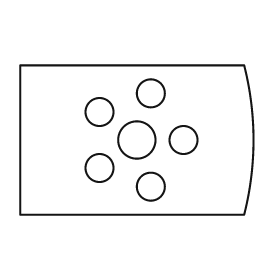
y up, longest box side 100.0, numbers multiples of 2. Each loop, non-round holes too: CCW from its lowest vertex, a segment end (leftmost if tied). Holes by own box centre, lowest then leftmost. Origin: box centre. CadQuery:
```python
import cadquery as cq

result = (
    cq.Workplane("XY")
    .moveTo(-50.0, -32.0)
    .lineTo(46.0, -32.0)
    .threePointArc((50.0, 0.0), (46.0, 32.0))
    .lineTo(-50.0, 32.0)
    .close()
    .moveTo(6.0, -20.0)
    .circle(6.0)
    .moveTo(-16.0, -12.0)
    .circle(6.0)
    .moveTo(0.0, 0.0)
    .circle(8.0)
    .moveTo(20.0, 0.0)
    .circle(6.0)
    .moveTo(-16.0, 12.0)
    .circle(6.0)
    .moveTo(6.0, 20.0)
    .circle(6.0)
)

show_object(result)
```